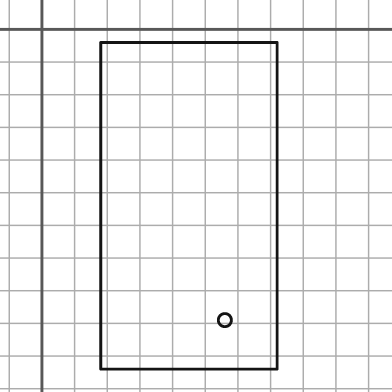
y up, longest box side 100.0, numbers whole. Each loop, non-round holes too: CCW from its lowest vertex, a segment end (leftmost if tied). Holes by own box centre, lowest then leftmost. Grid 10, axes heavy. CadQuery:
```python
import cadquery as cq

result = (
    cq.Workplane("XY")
    .moveTo(18.0, -104.0)
    .lineTo(72.0, -104.0)
    .lineTo(72.0, -4.0)
    .lineTo(18.0, -4.0)
    .close()
    .moveTo(56.0, -89.0)
    .circle(2.0)
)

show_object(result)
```